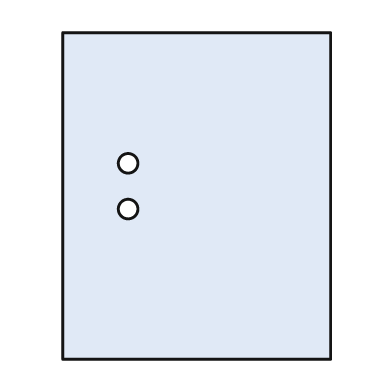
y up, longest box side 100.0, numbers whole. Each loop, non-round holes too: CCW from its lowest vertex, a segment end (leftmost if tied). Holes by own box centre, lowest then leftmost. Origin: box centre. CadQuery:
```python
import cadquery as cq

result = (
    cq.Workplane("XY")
    .moveTo(-41.0, -50.0)
    .lineTo(41.0, -50.0)
    .lineTo(41.0, 50.0)
    .lineTo(-41.0, 50.0)
    .close()
    .moveTo(-21.0, -4.0)
    .circle(3.0)
    .moveTo(-21.0, 10.0)
    .circle(3.0)
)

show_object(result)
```